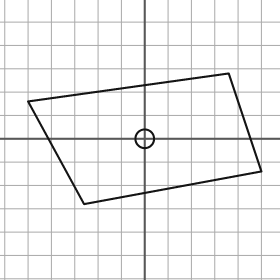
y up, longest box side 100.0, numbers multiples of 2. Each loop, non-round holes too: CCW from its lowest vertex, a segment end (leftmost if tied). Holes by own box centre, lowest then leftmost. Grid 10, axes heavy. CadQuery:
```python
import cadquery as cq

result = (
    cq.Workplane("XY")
    .moveTo(-26.0, -28.0)
    .lineTo(50.0, -14.0)
    .lineTo(36.0, 28.0)
    .lineTo(-50.0, 16.0)
    .close()
    .moveTo(0.0, 0.0)
    .circle(4.0)
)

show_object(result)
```